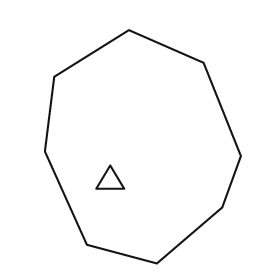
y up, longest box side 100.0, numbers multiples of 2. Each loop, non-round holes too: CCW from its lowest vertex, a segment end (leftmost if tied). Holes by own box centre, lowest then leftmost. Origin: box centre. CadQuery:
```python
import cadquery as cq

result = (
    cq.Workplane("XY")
    .moveTo(6.0, -50.0)
    .lineTo(34.0, -26.0)
    .lineTo(42.0, -4.0)
    .lineTo(26.0, 36.0)
    .lineTo(-6.0, 50.0)
    .lineTo(-38.0, 30.0)
    .lineTo(-42.0, -2.0)
    .lineTo(-24.0, -42.0)
    .close()
    .moveTo(-20.0, -18.0)
    .lineTo(-8.0, -18.0)
    .lineTo(-14.0, -8.0)
    .close()
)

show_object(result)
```